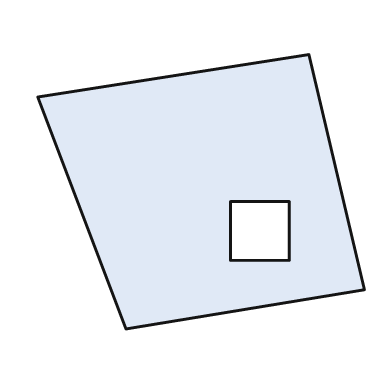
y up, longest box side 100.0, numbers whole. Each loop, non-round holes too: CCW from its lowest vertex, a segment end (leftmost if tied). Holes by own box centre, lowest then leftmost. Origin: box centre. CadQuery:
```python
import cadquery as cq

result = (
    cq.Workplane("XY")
    .moveTo(-23.0, -42.0)
    .lineTo(50.0, -30.0)
    .lineTo(33.0, 42.0)
    .lineTo(-50.0, 29.0)
    .close()
    .moveTo(9.0, -21.0)
    .lineTo(27.0, -21.0)
    .lineTo(27.0, -3.0)
    .lineTo(9.0, -3.0)
    .close()
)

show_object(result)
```